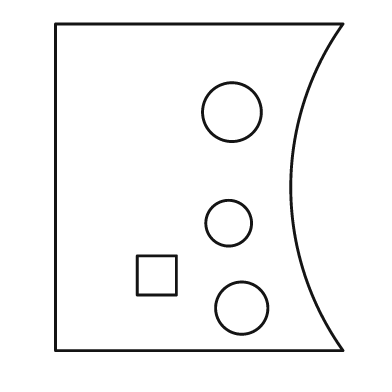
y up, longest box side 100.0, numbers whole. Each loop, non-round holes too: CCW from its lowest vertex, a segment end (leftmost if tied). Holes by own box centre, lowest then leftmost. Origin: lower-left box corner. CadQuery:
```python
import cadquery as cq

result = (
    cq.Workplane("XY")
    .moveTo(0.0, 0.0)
    .lineTo(88.0, 0.0)
    .threePointArc((72.0, 50.0), (88.0, 100.0))
    .lineTo(0.0, 100.0)
    .close()
    .moveTo(57.0, 13.0)
    .circle(8.0)
    .moveTo(25.0, 17.0)
    .lineTo(37.0, 17.0)
    .lineTo(37.0, 29.0)
    .lineTo(25.0, 29.0)
    .close()
    .moveTo(53.0, 39.0)
    .circle(7.0)
    .moveTo(54.0, 73.0)
    .circle(9.0)
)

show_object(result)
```